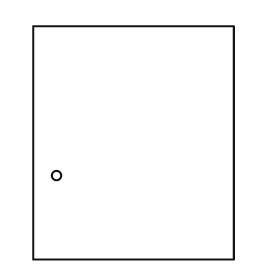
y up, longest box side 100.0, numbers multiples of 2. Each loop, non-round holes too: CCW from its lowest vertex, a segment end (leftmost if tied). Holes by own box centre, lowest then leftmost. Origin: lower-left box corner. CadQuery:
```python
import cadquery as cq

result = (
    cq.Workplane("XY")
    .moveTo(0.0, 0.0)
    .lineTo(86.0, 0.0)
    .lineTo(86.0, 100.0)
    .lineTo(0.0, 100.0)
    .close()
    .moveTo(10.0, 36.0)
    .circle(2.0)
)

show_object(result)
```